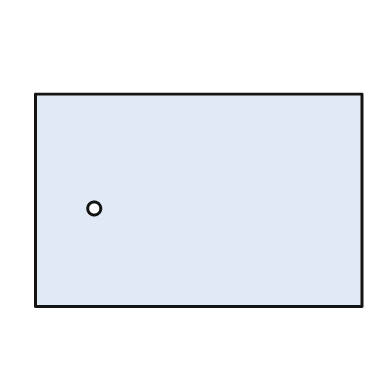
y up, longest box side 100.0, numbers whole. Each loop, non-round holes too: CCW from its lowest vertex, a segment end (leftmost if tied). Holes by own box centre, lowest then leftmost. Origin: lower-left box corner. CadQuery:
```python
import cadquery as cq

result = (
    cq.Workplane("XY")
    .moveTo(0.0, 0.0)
    .lineTo(100.0, 0.0)
    .lineTo(100.0, 65.0)
    .lineTo(0.0, 65.0)
    .close()
    .moveTo(18.0, 30.0)
    .circle(2.0)
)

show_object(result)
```